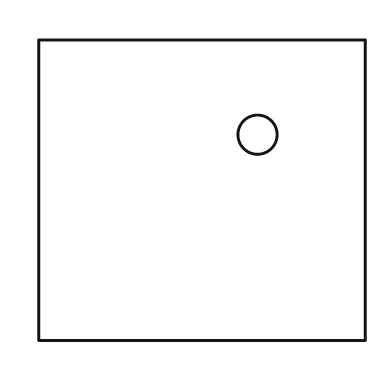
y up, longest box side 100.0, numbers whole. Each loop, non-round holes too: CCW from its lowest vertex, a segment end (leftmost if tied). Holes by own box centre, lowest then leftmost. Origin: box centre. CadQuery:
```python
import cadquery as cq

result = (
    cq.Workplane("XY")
    .moveTo(-50.0, -46.0)
    .lineTo(50.0, -46.0)
    .lineTo(50.0, 46.0)
    .lineTo(-50.0, 46.0)
    .close()
    .moveTo(17.0, 17.0)
    .circle(6.0)
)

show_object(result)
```